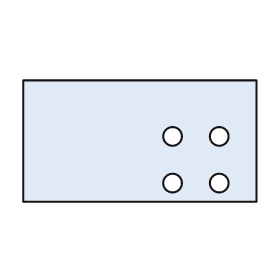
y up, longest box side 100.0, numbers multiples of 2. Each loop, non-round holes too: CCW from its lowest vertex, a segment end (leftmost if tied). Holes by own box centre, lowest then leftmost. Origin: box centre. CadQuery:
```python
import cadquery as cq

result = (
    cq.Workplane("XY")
    .moveTo(-50.0, -26.0)
    .lineTo(50.0, -26.0)
    .lineTo(50.0, 26.0)
    .lineTo(-50.0, 26.0)
    .close()
    .moveTo(14.0, -18.0)
    .circle(4.0)
    .moveTo(34.0, -18.0)
    .circle(4.0)
    .moveTo(14.0, 2.0)
    .circle(4.0)
    .moveTo(34.0, 2.0)
    .circle(4.0)
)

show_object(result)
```